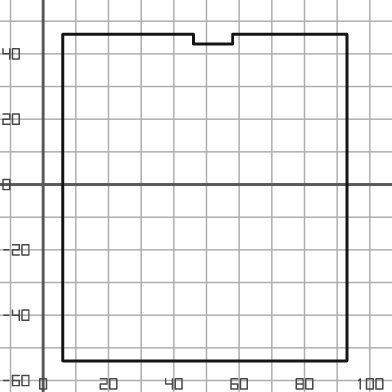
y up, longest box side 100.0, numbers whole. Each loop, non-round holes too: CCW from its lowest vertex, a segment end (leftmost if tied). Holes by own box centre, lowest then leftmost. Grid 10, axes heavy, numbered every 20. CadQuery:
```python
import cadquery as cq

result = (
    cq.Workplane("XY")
    .moveTo(6.0, -54.0)
    .lineTo(93.0, -54.0)
    .lineTo(93.0, 46.0)
    .lineTo(58.0, 46.0)
    .lineTo(58.0, 43.0)
    .lineTo(46.0, 43.0)
    .lineTo(46.0, 46.0)
    .lineTo(6.0, 46.0)
    .close()
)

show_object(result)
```